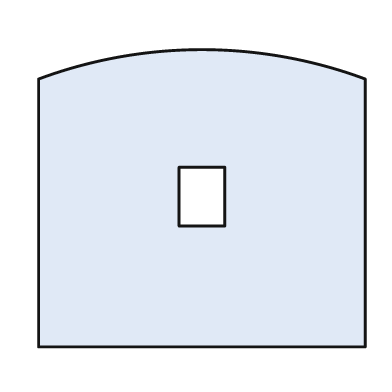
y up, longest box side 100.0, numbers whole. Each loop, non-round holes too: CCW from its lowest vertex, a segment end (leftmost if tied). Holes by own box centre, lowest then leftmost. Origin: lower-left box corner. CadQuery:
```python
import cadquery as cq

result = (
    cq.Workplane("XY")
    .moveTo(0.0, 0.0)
    .lineTo(100.0, 0.0)
    .lineTo(100.0, 82.0)
    .threePointArc((50.0, 91.0), (0.0, 82.0))
    .close()
    .moveTo(43.0, 37.0)
    .lineTo(57.0, 37.0)
    .lineTo(57.0, 55.0)
    .lineTo(43.0, 55.0)
    .close()
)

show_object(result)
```